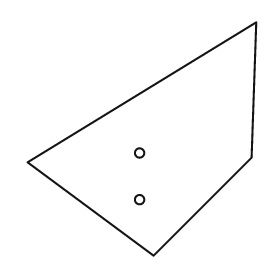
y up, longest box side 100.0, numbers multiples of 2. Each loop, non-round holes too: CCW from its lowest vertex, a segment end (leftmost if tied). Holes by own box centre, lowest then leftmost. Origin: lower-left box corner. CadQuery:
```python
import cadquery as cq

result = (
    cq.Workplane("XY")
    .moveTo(54.0, 0.0)
    .lineTo(96.0, 42.0)
    .lineTo(98.0, 100.0)
    .lineTo(0.0, 40.0)
    .close()
    .moveTo(48.0, 24.0)
    .circle(2.0)
    .moveTo(48.0, 44.0)
    .circle(2.0)
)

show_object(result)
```